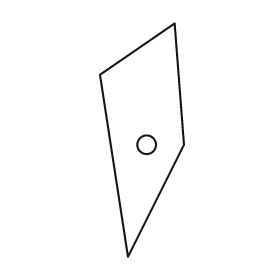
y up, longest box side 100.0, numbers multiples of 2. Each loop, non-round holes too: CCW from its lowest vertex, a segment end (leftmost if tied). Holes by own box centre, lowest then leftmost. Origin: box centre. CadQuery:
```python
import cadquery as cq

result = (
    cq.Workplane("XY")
    .moveTo(-6.0, -50.0)
    .lineTo(18.0, -2.0)
    .lineTo(14.0, 50.0)
    .lineTo(-18.0, 28.0)
    .close()
    .moveTo(2.0, -2.0)
    .circle(4.0)
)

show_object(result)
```